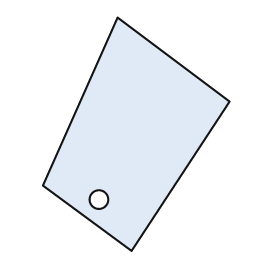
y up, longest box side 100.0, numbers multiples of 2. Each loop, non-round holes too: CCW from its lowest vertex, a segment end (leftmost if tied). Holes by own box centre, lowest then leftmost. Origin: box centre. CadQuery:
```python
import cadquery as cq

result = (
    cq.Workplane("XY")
    .moveTo(-2.0, -50.0)
    .lineTo(40.0, 14.0)
    .lineTo(-8.0, 50.0)
    .lineTo(-40.0, -22.0)
    .close()
    .moveTo(-16.0, -28.0)
    .circle(4.0)
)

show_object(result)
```